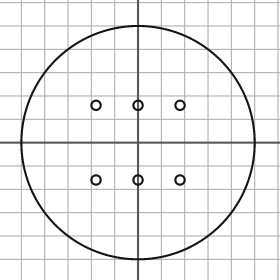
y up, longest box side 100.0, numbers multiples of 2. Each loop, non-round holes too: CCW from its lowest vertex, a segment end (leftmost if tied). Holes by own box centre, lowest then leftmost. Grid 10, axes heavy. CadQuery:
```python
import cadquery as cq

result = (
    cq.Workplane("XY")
    .moveTo(0.0, 0.0)
    .circle(50.0)
    .moveTo(-18.0, -16.0)
    .circle(2.0)
    .moveTo(0.0, -16.0)
    .circle(2.0)
    .moveTo(18.0, -16.0)
    .circle(2.0)
    .moveTo(-18.0, 16.0)
    .circle(2.0)
    .moveTo(0.0, 16.0)
    .circle(2.0)
    .moveTo(18.0, 16.0)
    .circle(2.0)
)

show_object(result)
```